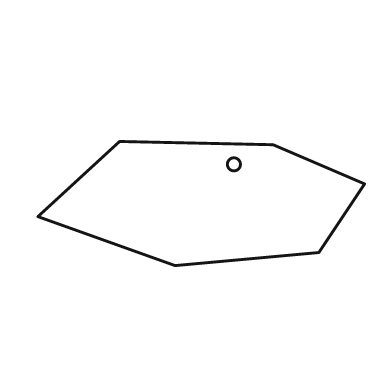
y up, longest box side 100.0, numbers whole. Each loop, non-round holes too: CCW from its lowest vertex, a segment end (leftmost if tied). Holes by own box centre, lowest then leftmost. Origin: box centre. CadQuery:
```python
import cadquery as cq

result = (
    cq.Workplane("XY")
    .moveTo(-8.0, -19.0)
    .lineTo(36.0, -15.0)
    .lineTo(50.0, 6.0)
    .lineTo(22.0, 18.0)
    .lineTo(-25.0, 19.0)
    .lineTo(-50.0, -4.0)
    .close()
    .moveTo(10.0, 12.0)
    .circle(2.0)
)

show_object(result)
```